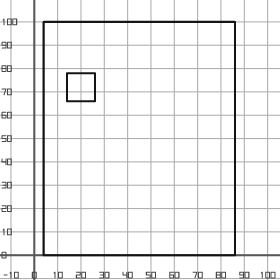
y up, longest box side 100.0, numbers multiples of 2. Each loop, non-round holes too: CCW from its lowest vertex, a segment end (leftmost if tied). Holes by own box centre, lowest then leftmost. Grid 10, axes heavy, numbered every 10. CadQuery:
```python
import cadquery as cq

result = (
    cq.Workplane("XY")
    .moveTo(4.0, 0.0)
    .lineTo(86.0, 0.0)
    .lineTo(86.0, 100.0)
    .lineTo(4.0, 100.0)
    .close()
    .moveTo(14.0, 66.0)
    .lineTo(26.0, 66.0)
    .lineTo(26.0, 78.0)
    .lineTo(14.0, 78.0)
    .close()
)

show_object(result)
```